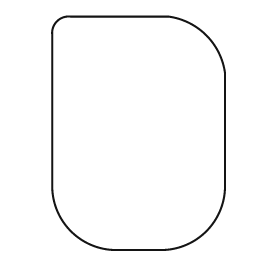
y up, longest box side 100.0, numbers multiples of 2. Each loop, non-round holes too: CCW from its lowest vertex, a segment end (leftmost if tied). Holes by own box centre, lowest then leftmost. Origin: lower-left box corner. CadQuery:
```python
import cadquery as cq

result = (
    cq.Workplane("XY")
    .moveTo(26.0, 0.0)
    .lineTo(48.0, 0.0)
    .threePointArc((66.0, 8.0), (74.0, 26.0))
    .lineTo(74.0, 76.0)
    .threePointArc((66.0, 92.0), (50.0, 100.0))
    .lineTo(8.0, 100.0)
    .threePointArc((2.0, 98.0), (0.0, 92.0))
    .lineTo(0.0, 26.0)
    .threePointArc((8.0, 8.0), (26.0, 0.0))
    .close()
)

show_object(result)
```